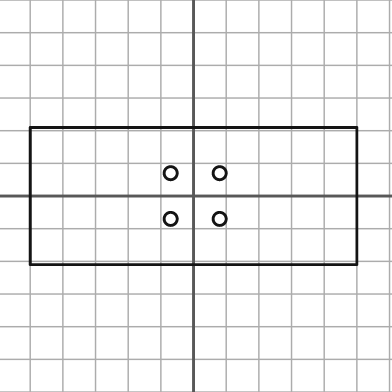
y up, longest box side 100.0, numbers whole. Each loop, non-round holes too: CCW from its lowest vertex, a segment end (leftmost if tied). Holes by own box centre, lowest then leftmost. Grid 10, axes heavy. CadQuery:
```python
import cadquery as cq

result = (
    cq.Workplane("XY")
    .moveTo(-50.0, -21.0)
    .lineTo(50.0, -21.0)
    .lineTo(50.0, 21.0)
    .lineTo(-50.0, 21.0)
    .close()
    .moveTo(-7.0, -7.0)
    .circle(2.0)
    .moveTo(8.0, -7.0)
    .circle(2.0)
    .moveTo(-7.0, 7.0)
    .circle(2.0)
    .moveTo(8.0, 7.0)
    .circle(2.0)
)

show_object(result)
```